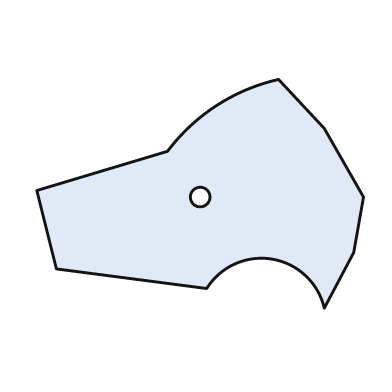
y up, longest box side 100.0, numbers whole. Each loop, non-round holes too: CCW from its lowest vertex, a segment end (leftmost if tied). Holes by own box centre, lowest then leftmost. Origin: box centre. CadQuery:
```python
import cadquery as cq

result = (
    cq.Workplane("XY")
    .moveTo(38.0, -35.0)
    .lineTo(47.0, -18.0)
    .lineTo(50.0, -1.0)
    .lineTo(38.0, 20.0)
    .lineTo(24.0, 35.0)
    .threePointArc((5.0, 27.0), (-10.0, 13.0))
    .lineTo(-50.0, 1.0)
    .lineTo(-44.0, -23.0)
    .lineTo(2.0, -29.0)
    .threePointArc((22.0, -20.0), (38.0, -35.0))
    .close()
    .moveTo(0.0, -1.0)
    .circle(3.0)
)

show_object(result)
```